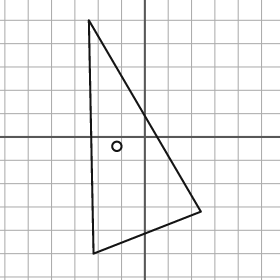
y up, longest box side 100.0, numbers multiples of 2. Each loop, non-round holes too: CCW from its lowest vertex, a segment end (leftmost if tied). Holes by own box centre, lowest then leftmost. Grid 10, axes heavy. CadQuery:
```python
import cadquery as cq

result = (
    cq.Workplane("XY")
    .moveTo(-22.0, -50.0)
    .lineTo(24.0, -32.0)
    .lineTo(-24.0, 50.0)
    .close()
    .moveTo(-12.0, -4.0)
    .circle(2.0)
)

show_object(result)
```